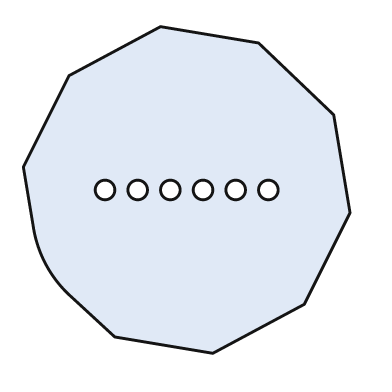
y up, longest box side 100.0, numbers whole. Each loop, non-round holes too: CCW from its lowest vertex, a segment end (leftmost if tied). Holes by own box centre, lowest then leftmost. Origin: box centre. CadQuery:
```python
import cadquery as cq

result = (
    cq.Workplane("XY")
    .moveTo(8.0, -50.0)
    .lineTo(36.0, -35.0)
    .lineTo(50.0, -7.0)
    .lineTo(45.0, 23.0)
    .lineTo(22.0, 45.0)
    .lineTo(-8.0, 50.0)
    .lineTo(-36.0, 35.0)
    .lineTo(-50.0, 7.0)
    .lineTo(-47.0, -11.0)
    .threePointArc((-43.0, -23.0), (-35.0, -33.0))
    .lineTo(-22.0, -45.0)
    .close()
    .moveTo(-25.0, 0.0)
    .circle(3.0)
    .moveTo(-15.0, 0.0)
    .circle(3.0)
    .moveTo(-5.0, 0.0)
    .circle(3.0)
    .moveTo(5.0, 0.0)
    .circle(3.0)
    .moveTo(15.0, 0.0)
    .circle(3.0)
    .moveTo(25.0, 0.0)
    .circle(3.0)
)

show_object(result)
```